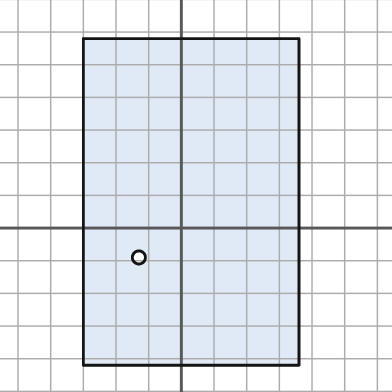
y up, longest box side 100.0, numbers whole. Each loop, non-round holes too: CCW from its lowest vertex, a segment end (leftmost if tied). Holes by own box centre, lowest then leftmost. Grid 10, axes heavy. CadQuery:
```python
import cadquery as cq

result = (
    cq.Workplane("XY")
    .moveTo(-30.0, -42.0)
    .lineTo(36.0, -42.0)
    .lineTo(36.0, 58.0)
    .lineTo(-30.0, 58.0)
    .close()
    .moveTo(-13.0, -9.0)
    .circle(2.0)
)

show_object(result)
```